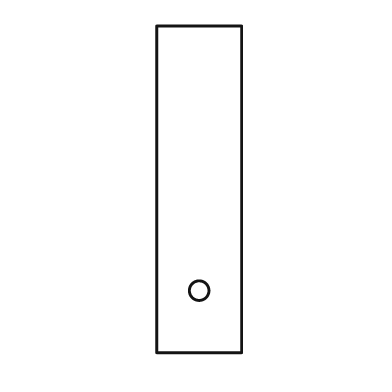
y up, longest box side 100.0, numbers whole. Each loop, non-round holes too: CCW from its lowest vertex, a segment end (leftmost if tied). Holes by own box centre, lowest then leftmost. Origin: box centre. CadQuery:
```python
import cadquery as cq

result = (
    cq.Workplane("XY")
    .moveTo(-13.0, -50.0)
    .lineTo(13.0, -50.0)
    .lineTo(13.0, 50.0)
    .lineTo(-13.0, 50.0)
    .close()
    .moveTo(0.0, -31.0)
    .circle(3.0)
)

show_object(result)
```